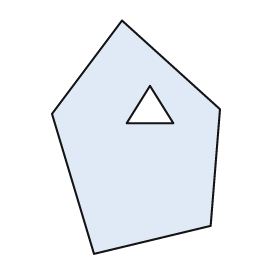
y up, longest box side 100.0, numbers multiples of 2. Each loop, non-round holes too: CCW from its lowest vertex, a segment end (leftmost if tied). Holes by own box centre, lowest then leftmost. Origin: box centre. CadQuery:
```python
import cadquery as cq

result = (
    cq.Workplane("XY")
    .moveTo(-18.0, -50.0)
    .lineTo(32.0, -38.0)
    .lineTo(36.0, 12.0)
    .lineTo(-6.0, 50.0)
    .lineTo(-36.0, 10.0)
    .close()
    .moveTo(-4.0, 6.0)
    .lineTo(16.0, 6.0)
    .lineTo(6.0, 22.0)
    .close()
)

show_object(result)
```